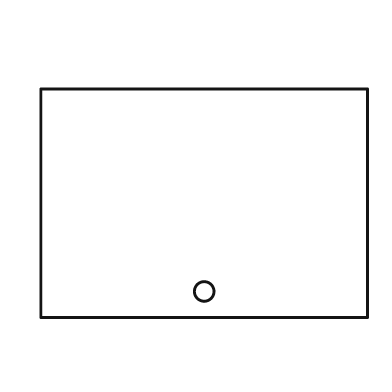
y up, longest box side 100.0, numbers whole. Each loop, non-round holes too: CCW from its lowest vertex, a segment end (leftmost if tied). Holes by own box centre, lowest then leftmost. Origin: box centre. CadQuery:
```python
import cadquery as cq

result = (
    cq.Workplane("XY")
    .moveTo(-50.0, -35.0)
    .lineTo(50.0, -35.0)
    .lineTo(50.0, 35.0)
    .lineTo(-50.0, 35.0)
    .close()
    .moveTo(0.0, -27.0)
    .circle(3.0)
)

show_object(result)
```